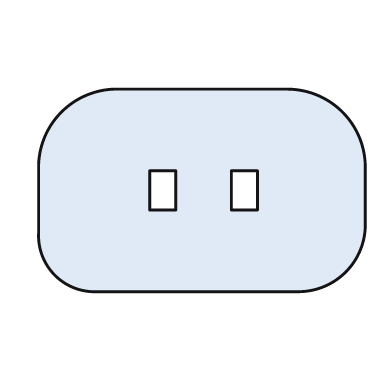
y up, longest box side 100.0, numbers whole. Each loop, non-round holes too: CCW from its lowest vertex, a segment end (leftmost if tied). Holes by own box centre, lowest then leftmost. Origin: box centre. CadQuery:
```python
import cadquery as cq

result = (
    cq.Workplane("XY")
    .moveTo(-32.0, -31.0)
    .lineTo(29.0, -31.0)
    .threePointArc((44.0, -25.0), (50.0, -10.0))
    .lineTo(50.0, 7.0)
    .threePointArc((43.0, 24.0), (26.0, 31.0))
    .lineTo(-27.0, 31.0)
    .threePointArc((-43.0, 24.0), (-50.0, 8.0))
    .lineTo(-50.0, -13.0)
    .threePointArc((-45.0, -26.0), (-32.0, -31.0))
    .close()
    .moveTo(-16.0, -6.0)
    .lineTo(-8.0, -6.0)
    .lineTo(-8.0, 6.0)
    .lineTo(-16.0, 6.0)
    .close()
    .moveTo(9.0, -6.0)
    .lineTo(17.0, -6.0)
    .lineTo(17.0, 6.0)
    .lineTo(9.0, 6.0)
    .close()
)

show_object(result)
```